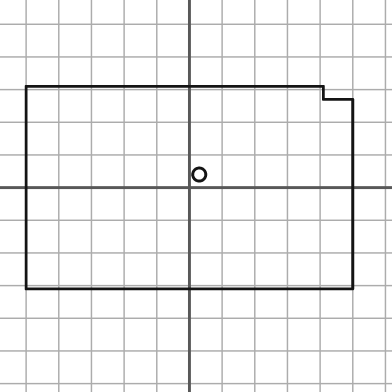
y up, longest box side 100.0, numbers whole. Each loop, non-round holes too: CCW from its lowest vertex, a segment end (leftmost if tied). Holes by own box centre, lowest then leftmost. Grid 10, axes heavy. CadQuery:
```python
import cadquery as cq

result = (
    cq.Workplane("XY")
    .moveTo(-50.0, -31.0)
    .lineTo(50.0, -31.0)
    .lineTo(50.0, 27.0)
    .lineTo(41.0, 27.0)
    .lineTo(41.0, 31.0)
    .lineTo(-50.0, 31.0)
    .close()
    .moveTo(3.0, 4.0)
    .circle(2.0)
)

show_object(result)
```